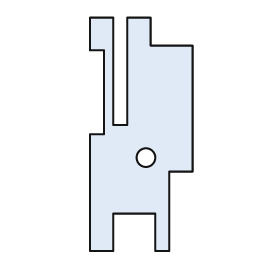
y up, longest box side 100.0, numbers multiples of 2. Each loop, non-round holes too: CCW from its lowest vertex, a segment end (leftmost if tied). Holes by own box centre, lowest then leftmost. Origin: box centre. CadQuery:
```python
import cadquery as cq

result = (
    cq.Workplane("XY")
    .moveTo(-22.0, -50.0)
    .lineTo(-12.0, -50.0)
    .lineTo(-12.0, -34.0)
    .lineTo(6.0, -34.0)
    .lineTo(6.0, -50.0)
    .lineTo(12.0, -50.0)
    .lineTo(12.0, -16.0)
    .lineTo(22.0, -16.0)
    .lineTo(22.0, 38.0)
    .lineTo(4.0, 38.0)
    .lineTo(4.0, 50.0)
    .lineTo(-6.0, 50.0)
    .lineTo(-6.0, 4.0)
    .lineTo(-12.0, 4.0)
    .lineTo(-12.0, 50.0)
    .lineTo(-22.0, 50.0)
    .lineTo(-22.0, 36.0)
    .lineTo(-16.0, 36.0)
    .lineTo(-16.0, 0.0)
    .lineTo(-22.0, 0.0)
    .close()
    .moveTo(2.0, -10.0)
    .circle(4.0)
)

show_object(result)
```